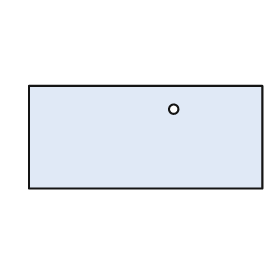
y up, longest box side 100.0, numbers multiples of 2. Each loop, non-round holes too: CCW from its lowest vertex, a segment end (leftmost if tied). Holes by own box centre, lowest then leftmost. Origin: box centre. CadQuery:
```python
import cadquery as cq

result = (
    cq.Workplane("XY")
    .moveTo(-50.0, -22.0)
    .lineTo(50.0, -22.0)
    .lineTo(50.0, 22.0)
    .lineTo(-50.0, 22.0)
    .close()
    .moveTo(12.0, 12.0)
    .circle(2.0)
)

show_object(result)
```